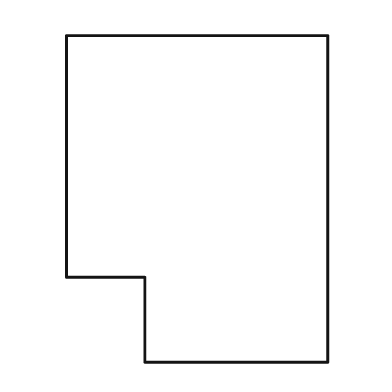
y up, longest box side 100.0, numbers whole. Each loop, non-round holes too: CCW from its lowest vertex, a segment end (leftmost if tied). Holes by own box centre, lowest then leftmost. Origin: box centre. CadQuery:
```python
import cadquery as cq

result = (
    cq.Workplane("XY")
    .moveTo(-16.0, -50.0)
    .lineTo(40.0, -50.0)
    .lineTo(40.0, 50.0)
    .lineTo(-40.0, 50.0)
    .lineTo(-40.0, -24.0)
    .lineTo(-16.0, -24.0)
    .close()
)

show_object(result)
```